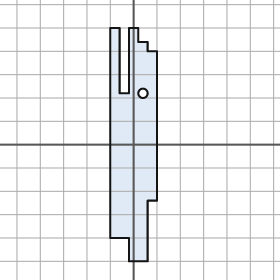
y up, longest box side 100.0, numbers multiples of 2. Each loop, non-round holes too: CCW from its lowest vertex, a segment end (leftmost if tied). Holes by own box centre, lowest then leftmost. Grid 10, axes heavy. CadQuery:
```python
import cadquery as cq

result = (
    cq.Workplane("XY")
    .moveTo(-2.0, -50.0)
    .lineTo(6.0, -50.0)
    .lineTo(6.0, -24.0)
    .lineTo(10.0, -24.0)
    .lineTo(10.0, 40.0)
    .lineTo(6.0, 40.0)
    .lineTo(6.0, 44.0)
    .lineTo(2.0, 44.0)
    .lineTo(2.0, 50.0)
    .lineTo(-2.0, 50.0)
    .lineTo(-2.0, 22.0)
    .lineTo(-6.0, 22.0)
    .lineTo(-6.0, 50.0)
    .lineTo(-10.0, 50.0)
    .lineTo(-10.0, -40.0)
    .lineTo(-2.0, -40.0)
    .close()
    .moveTo(4.0, 22.0)
    .circle(2.0)
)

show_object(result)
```